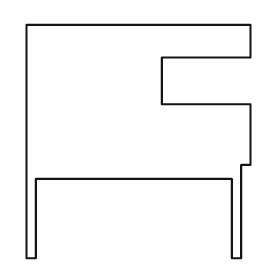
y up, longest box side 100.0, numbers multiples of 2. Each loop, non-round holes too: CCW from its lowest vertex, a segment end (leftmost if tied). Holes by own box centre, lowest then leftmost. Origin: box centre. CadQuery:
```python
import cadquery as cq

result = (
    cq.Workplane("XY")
    .moveTo(-48.0, -50.0)
    .lineTo(-44.0, -50.0)
    .lineTo(-44.0, -16.0)
    .lineTo(40.0, -16.0)
    .lineTo(40.0, -50.0)
    .lineTo(44.0, -50.0)
    .lineTo(44.0, -10.0)
    .lineTo(48.0, -10.0)
    .lineTo(48.0, 16.0)
    .lineTo(10.0, 16.0)
    .lineTo(10.0, 36.0)
    .lineTo(48.0, 36.0)
    .lineTo(48.0, 50.0)
    .lineTo(-48.0, 50.0)
    .close()
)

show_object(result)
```